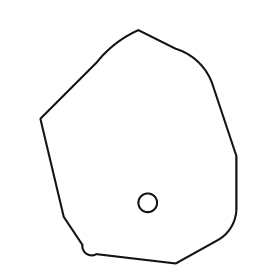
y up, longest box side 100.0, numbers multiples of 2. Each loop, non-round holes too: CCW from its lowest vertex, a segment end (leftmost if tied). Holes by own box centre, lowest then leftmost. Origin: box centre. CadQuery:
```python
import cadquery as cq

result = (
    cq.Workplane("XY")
    .moveTo(16.0, -50.0)
    .lineTo(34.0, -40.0)
    .threePointArc((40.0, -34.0), (42.0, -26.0))
    .lineTo(42.0, -4.0)
    .lineTo(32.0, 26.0)
    .threePointArc((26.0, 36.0), (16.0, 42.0))
    .lineTo(0.0, 50.0)
    .threePointArc((-10.0, 44.0), (-18.0, 36.0))
    .lineTo(-42.0, 12.0)
    .lineTo(-32.0, -30.0)
    .lineTo(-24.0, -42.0)
    .threePointArc((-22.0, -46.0), (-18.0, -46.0))
    .close()
    .moveTo(4.0, -24.0)
    .circle(4.0)
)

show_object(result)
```